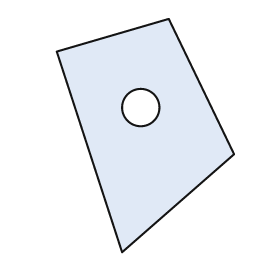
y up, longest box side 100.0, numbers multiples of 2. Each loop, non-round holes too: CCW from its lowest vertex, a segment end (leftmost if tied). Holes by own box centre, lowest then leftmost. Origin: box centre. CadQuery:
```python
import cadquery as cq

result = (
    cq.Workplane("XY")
    .moveTo(-10.0, -50.0)
    .lineTo(38.0, -8.0)
    .lineTo(10.0, 50.0)
    .lineTo(-38.0, 36.0)
    .close()
    .moveTo(-2.0, 12.0)
    .circle(8.0)
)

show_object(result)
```